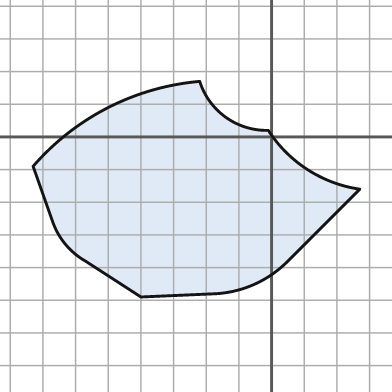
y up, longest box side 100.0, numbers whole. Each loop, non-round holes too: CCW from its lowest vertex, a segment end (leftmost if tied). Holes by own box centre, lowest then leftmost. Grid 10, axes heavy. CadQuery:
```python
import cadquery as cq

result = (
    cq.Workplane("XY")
    .moveTo(-40.0, -49.0)
    .lineTo(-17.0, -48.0)
    .threePointArc((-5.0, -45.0), (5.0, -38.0))
    .lineTo(27.0, -16.0)
    .threePointArc((11.0, -10.0), (-1.0, 2.0))
    .threePointArc((-14.0, 6.0), (-22.0, 17.0))
    .threePointArc((-50.0, 9.0), (-73.0, -9.0))
    .lineTo(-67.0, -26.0)
    .threePointArc((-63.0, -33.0), (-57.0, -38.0))
    .close()
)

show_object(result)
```